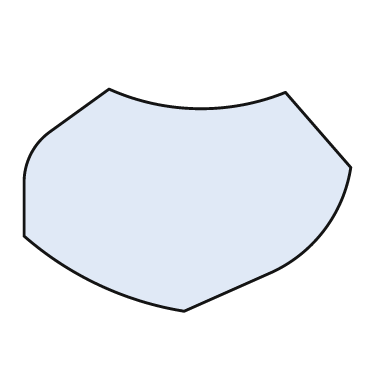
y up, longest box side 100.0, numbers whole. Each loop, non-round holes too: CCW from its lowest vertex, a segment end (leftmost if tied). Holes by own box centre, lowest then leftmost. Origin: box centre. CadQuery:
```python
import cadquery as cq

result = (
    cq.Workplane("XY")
    .moveTo(-1.0, -34.0)
    .lineTo(26.0, -22.0)
    .threePointArc((42.0, -9.0), (50.0, 10.0))
    .lineTo(30.0, 33.0)
    .threePointArc((3.0, 28.0), (-24.0, 34.0))
    .lineTo(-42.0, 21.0)
    .threePointArc((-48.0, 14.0), (-50.0, 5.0))
    .lineTo(-50.0, -11.0)
    .threePointArc((-27.0, -26.0), (-1.0, -34.0))
    .close()
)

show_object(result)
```